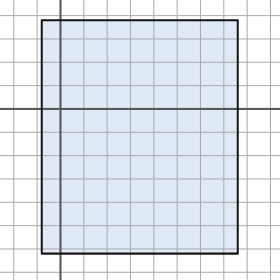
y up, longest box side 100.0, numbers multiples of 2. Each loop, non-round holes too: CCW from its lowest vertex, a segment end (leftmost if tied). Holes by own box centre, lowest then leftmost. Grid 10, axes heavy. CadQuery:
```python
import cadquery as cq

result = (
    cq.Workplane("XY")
    .moveTo(-8.0, -62.0)
    .lineTo(76.0, -62.0)
    .lineTo(76.0, 38.0)
    .lineTo(-8.0, 38.0)
    .close()
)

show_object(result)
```